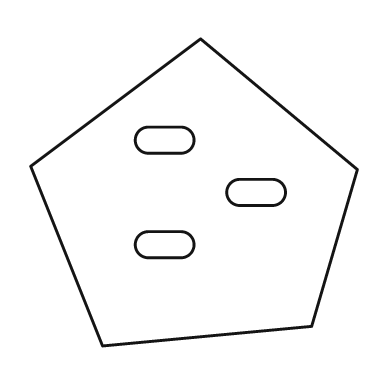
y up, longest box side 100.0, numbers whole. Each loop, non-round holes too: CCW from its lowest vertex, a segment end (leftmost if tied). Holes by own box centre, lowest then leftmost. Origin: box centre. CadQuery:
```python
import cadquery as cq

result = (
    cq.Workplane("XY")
    .moveTo(-28.0, -47.0)
    .lineTo(36.0, -41.0)
    .lineTo(50.0, 7.0)
    .lineTo(2.0, 47.0)
    .lineTo(-50.0, 8.0)
    .close()
    .moveTo(-14.0, -20.0)
    .lineTo(-4.0, -20.0)
    .threePointArc((0.0, -16.0), (-4.0, -12.0))
    .lineTo(-14.0, -12.0)
    .threePointArc((-18.0, -16.0), (-14.0, -20.0))
    .close()
    .moveTo(14.0, -4.0)
    .lineTo(24.0, -4.0)
    .threePointArc((28.0, 0.0), (24.0, 4.0))
    .lineTo(14.0, 4.0)
    .threePointArc((10.0, 0.0), (14.0, -4.0))
    .close()
    .moveTo(-14.0, 12.0)
    .lineTo(-4.0, 12.0)
    .threePointArc((0.0, 16.0), (-4.0, 20.0))
    .lineTo(-14.0, 20.0)
    .threePointArc((-18.0, 16.0), (-14.0, 12.0))
    .close()
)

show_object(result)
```